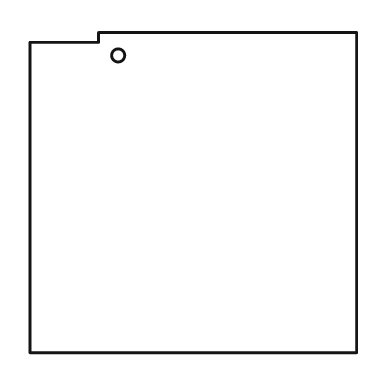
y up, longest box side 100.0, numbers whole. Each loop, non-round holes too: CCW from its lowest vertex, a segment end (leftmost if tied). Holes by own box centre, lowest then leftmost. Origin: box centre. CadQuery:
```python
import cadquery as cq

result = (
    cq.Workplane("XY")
    .moveTo(-50.0, -49.0)
    .lineTo(50.0, -49.0)
    .lineTo(50.0, 49.0)
    .lineTo(-29.0, 49.0)
    .lineTo(-29.0, 46.0)
    .lineTo(-50.0, 46.0)
    .close()
    .moveTo(-23.0, 42.0)
    .circle(2.0)
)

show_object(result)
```